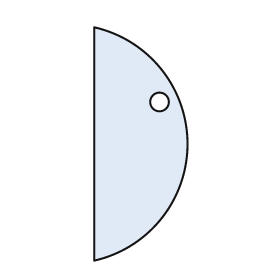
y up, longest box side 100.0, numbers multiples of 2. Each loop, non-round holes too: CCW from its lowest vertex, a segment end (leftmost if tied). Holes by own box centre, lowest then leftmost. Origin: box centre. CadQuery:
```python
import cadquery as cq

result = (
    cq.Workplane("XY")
    .moveTo(-20.0, -50.0)
    .threePointArc((20.0, 0.0), (-20.0, 50.0))
    .close()
    .moveTo(8.0, 18.0)
    .circle(4.0)
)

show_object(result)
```